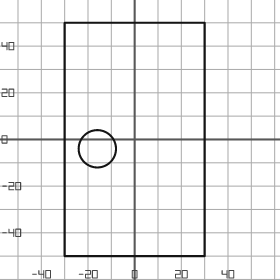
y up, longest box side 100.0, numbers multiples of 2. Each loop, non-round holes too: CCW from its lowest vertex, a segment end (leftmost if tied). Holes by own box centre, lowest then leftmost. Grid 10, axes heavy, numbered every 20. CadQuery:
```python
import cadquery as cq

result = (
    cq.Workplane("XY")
    .moveTo(-30.0, -50.0)
    .lineTo(30.0, -50.0)
    .lineTo(30.0, 50.0)
    .lineTo(-30.0, 50.0)
    .close()
    .moveTo(-16.0, -4.0)
    .circle(8.0)
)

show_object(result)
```